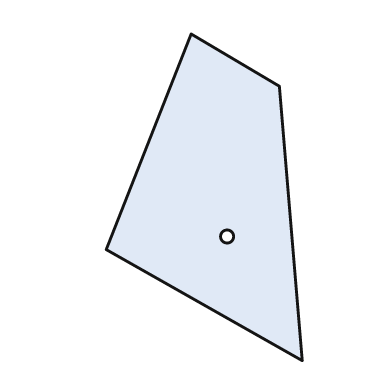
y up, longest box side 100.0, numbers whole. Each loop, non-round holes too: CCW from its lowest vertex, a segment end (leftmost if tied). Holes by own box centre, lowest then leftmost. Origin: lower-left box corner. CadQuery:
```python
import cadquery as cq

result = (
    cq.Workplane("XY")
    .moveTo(60.0, 0.0)
    .lineTo(53.0, 84.0)
    .lineTo(26.0, 100.0)
    .lineTo(0.0, 34.0)
    .close()
    .moveTo(37.0, 38.0)
    .circle(2.0)
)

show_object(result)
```